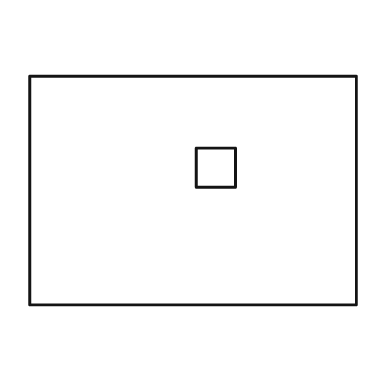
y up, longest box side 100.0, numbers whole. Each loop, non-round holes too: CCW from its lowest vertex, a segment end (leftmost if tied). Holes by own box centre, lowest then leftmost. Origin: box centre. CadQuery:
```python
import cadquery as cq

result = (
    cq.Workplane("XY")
    .moveTo(-50.0, -35.0)
    .lineTo(50.0, -35.0)
    .lineTo(50.0, 35.0)
    .lineTo(-50.0, 35.0)
    .close()
    .moveTo(1.0, 1.0)
    .lineTo(13.0, 1.0)
    .lineTo(13.0, 13.0)
    .lineTo(1.0, 13.0)
    .close()
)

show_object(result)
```